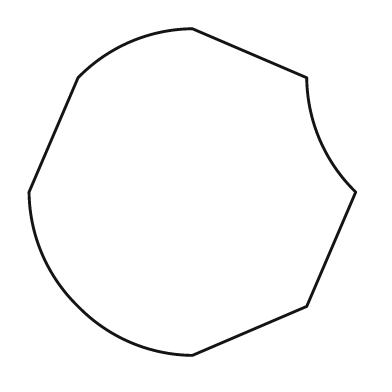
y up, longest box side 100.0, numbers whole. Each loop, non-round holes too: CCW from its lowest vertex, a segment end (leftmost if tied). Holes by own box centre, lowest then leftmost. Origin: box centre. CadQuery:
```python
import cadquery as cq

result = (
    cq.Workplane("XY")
    .moveTo(0.0, -50.0)
    .lineTo(35.0, -35.0)
    .lineTo(50.0, 0.0)
    .threePointArc((39.0, 16.0), (35.0, 35.0))
    .lineTo(0.0, 50.0)
    .threePointArc((-19.0, 46.0), (-35.0, 35.0))
    .lineTo(-50.0, 0.0)
    .threePointArc((-46.0, -19.0), (-35.0, -35.0))
    .threePointArc((-19.0, -46.0), (0.0, -50.0))
    .close()
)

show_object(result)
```